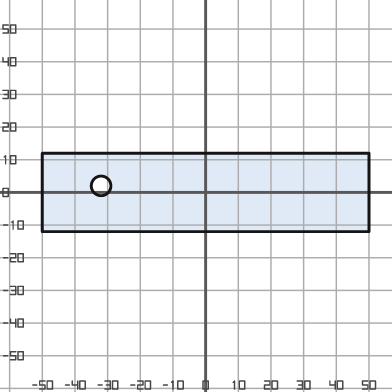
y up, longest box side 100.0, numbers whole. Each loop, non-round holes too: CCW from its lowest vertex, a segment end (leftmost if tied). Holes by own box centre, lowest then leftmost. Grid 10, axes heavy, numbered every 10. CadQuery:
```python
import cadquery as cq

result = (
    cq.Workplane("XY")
    .moveTo(-50.0, -12.0)
    .lineTo(50.0, -12.0)
    .lineTo(50.0, 12.0)
    .lineTo(-50.0, 12.0)
    .close()
    .moveTo(-32.0, 2.0)
    .circle(3.0)
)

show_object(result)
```